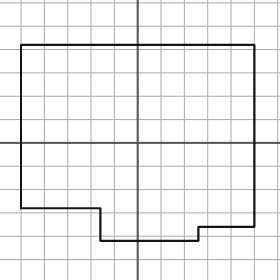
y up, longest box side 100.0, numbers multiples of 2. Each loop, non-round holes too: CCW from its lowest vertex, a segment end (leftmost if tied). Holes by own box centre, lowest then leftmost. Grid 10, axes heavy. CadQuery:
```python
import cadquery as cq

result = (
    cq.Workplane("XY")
    .moveTo(-16.0, -42.0)
    .lineTo(26.0, -42.0)
    .lineTo(26.0, -36.0)
    .lineTo(50.0, -36.0)
    .lineTo(50.0, 42.0)
    .lineTo(-50.0, 42.0)
    .lineTo(-50.0, -28.0)
    .lineTo(-16.0, -28.0)
    .close()
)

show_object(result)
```